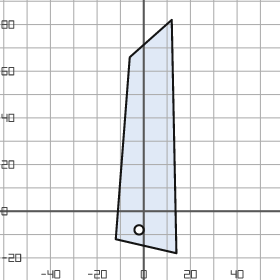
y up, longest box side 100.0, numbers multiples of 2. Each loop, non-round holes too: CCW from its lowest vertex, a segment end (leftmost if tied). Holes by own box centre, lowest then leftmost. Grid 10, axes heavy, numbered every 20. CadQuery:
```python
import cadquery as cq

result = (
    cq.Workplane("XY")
    .moveTo(14.0, -18.0)
    .lineTo(12.0, 82.0)
    .lineTo(-6.0, 66.0)
    .lineTo(-12.0, -12.0)
    .close()
    .moveTo(-2.0, -8.0)
    .circle(2.0)
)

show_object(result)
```